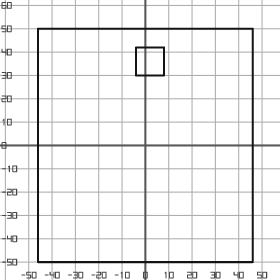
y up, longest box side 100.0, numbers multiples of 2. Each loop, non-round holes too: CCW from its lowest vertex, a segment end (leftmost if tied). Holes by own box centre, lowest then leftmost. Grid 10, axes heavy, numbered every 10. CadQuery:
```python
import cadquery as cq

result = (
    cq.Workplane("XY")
    .moveTo(-46.0, -50.0)
    .lineTo(46.0, -50.0)
    .lineTo(46.0, 50.0)
    .lineTo(-46.0, 50.0)
    .close()
    .moveTo(-4.0, 30.0)
    .lineTo(8.0, 30.0)
    .lineTo(8.0, 42.0)
    .lineTo(-4.0, 42.0)
    .close()
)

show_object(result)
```